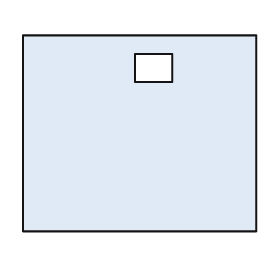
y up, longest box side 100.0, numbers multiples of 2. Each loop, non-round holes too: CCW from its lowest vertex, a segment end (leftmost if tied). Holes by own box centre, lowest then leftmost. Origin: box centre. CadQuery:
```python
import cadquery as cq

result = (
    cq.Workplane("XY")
    .moveTo(-50.0, -42.0)
    .lineTo(50.0, -42.0)
    .lineTo(50.0, 42.0)
    .lineTo(-50.0, 42.0)
    .close()
    .moveTo(-2.0, 22.0)
    .lineTo(14.0, 22.0)
    .lineTo(14.0, 34.0)
    .lineTo(-2.0, 34.0)
    .close()
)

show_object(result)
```